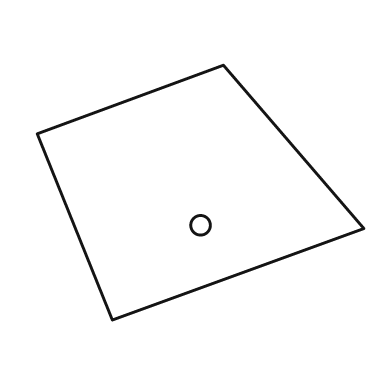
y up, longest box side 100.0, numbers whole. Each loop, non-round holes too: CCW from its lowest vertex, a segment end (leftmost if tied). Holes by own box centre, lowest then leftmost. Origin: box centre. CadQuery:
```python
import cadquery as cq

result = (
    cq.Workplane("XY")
    .moveTo(-27.0, -39.0)
    .lineTo(50.0, -11.0)
    .lineTo(7.0, 39.0)
    .lineTo(-50.0, 18.0)
    .close()
    .moveTo(0.0, -10.0)
    .circle(3.0)
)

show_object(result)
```